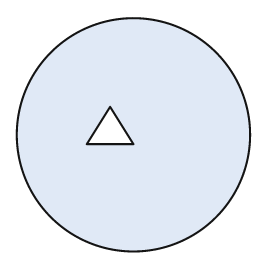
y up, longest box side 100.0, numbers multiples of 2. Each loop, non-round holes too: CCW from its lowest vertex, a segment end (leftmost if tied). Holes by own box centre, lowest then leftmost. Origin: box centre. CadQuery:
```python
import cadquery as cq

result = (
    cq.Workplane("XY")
    .moveTo(0.0, 0.0)
    .circle(50.0)
    .moveTo(-20.0, -4.0)
    .lineTo(0.0, -4.0)
    .lineTo(-10.0, 12.0)
    .close()
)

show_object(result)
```